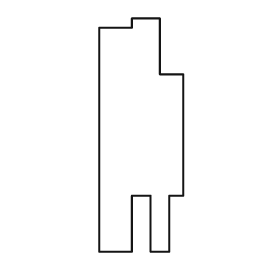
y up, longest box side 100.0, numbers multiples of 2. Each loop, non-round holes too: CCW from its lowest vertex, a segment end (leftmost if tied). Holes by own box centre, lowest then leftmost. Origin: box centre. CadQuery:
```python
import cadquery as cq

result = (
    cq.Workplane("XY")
    .moveTo(-18.0, -50.0)
    .lineTo(-4.0, -50.0)
    .lineTo(-4.0, -26.0)
    .lineTo(4.0, -26.0)
    .lineTo(4.0, -50.0)
    .lineTo(12.0, -50.0)
    .lineTo(12.0, -26.0)
    .lineTo(18.0, -26.0)
    .lineTo(18.0, 26.0)
    .lineTo(8.0, 26.0)
    .lineTo(8.0, 50.0)
    .lineTo(-4.0, 50.0)
    .lineTo(-4.0, 46.0)
    .lineTo(-18.0, 46.0)
    .close()
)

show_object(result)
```